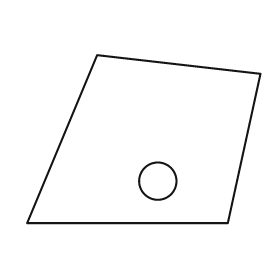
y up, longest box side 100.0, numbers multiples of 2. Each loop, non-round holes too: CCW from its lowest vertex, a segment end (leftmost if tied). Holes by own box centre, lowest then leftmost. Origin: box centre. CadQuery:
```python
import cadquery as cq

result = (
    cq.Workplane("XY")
    .moveTo(-50.0, -36.0)
    .lineTo(36.0, -36.0)
    .lineTo(50.0, 28.0)
    .lineTo(-20.0, 36.0)
    .close()
    .moveTo(6.0, -18.0)
    .circle(8.0)
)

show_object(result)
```